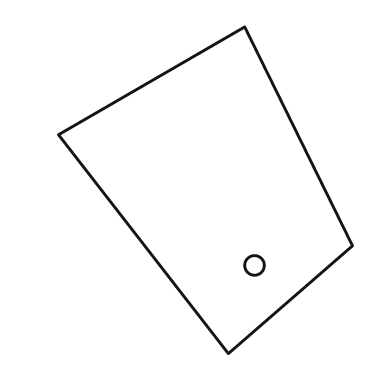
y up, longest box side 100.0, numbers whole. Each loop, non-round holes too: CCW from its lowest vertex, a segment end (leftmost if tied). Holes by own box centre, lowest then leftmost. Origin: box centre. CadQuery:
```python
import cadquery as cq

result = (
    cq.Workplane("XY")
    .moveTo(7.0, -50.0)
    .lineTo(45.0, -17.0)
    .lineTo(12.0, 50.0)
    .lineTo(-45.0, 17.0)
    .close()
    .moveTo(15.0, -23.0)
    .circle(3.0)
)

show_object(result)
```